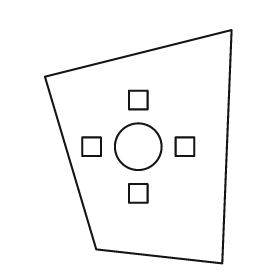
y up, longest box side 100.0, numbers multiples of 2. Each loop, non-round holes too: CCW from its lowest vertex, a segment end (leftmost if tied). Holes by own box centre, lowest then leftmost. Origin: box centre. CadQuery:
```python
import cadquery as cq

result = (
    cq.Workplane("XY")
    .moveTo(36.0, -50.0)
    .lineTo(40.0, 50.0)
    .lineTo(-40.0, 30.0)
    .lineTo(-18.0, -44.0)
    .close()
    .moveTo(-4.0, -24.0)
    .lineTo(4.0, -24.0)
    .lineTo(4.0, -16.0)
    .lineTo(-4.0, -16.0)
    .close()
    .moveTo(-24.0, -4.0)
    .lineTo(-16.0, -4.0)
    .lineTo(-16.0, 4.0)
    .lineTo(-24.0, 4.0)
    .close()
    .moveTo(0.0, 0.0)
    .circle(10.0)
    .moveTo(16.0, -4.0)
    .lineTo(24.0, -4.0)
    .lineTo(24.0, 4.0)
    .lineTo(16.0, 4.0)
    .close()
    .moveTo(-4.0, 16.0)
    .lineTo(4.0, 16.0)
    .lineTo(4.0, 24.0)
    .lineTo(-4.0, 24.0)
    .close()
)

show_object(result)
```